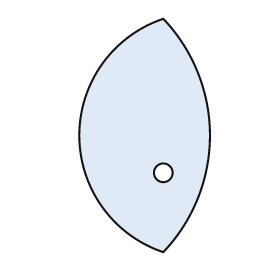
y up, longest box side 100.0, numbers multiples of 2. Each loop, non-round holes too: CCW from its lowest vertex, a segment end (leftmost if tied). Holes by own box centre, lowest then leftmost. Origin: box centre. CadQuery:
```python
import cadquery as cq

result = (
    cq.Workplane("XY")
    .moveTo(8.0, -50.0)
    .threePointArc((28.0, 0.0), (8.0, 50.0))
    .threePointArc((-28.0, 0.0), (8.0, -50.0))
    .close()
    .moveTo(8.0, -16.0)
    .circle(4.0)
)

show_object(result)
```